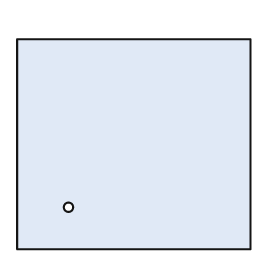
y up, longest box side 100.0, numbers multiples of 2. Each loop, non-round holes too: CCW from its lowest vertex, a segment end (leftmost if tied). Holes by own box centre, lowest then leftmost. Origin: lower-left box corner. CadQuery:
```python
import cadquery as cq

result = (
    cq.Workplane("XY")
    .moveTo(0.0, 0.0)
    .lineTo(100.0, 0.0)
    .lineTo(100.0, 90.0)
    .lineTo(0.0, 90.0)
    .close()
    .moveTo(22.0, 18.0)
    .circle(2.0)
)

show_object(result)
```